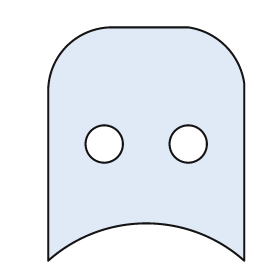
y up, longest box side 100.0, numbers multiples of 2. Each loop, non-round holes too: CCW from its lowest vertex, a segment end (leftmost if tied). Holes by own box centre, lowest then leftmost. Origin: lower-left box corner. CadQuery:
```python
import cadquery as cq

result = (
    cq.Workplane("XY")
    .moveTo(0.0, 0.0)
    .threePointArc((42.0, 16.0), (84.0, 0.0))
    .lineTo(84.0, 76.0)
    .threePointArc((76.0, 92.0), (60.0, 100.0))
    .lineTo(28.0, 100.0)
    .threePointArc((8.0, 92.0), (0.0, 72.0))
    .close()
    .moveTo(24.0, 50.0)
    .circle(8.0)
    .moveTo(60.0, 50.0)
    .circle(8.0)
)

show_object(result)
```